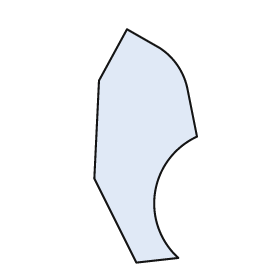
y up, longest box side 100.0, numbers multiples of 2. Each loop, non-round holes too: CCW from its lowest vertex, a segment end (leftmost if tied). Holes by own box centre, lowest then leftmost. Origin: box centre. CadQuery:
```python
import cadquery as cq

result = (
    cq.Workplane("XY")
    .moveTo(-4.0, -50.0)
    .lineTo(14.0, -48.0)
    .threePointArc((4.0, -20.0), (22.0, 4.0))
    .lineTo(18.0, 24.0)
    .threePointArc((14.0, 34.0), (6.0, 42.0))
    .lineTo(-8.0, 50.0)
    .lineTo(-20.0, 28.0)
    .lineTo(-22.0, -14.0)
    .close()
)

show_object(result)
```